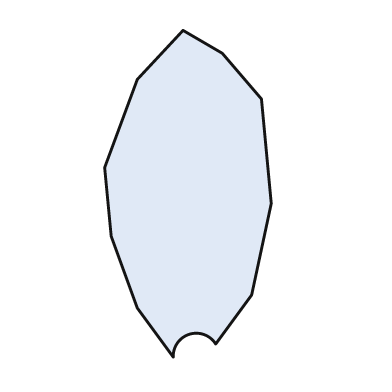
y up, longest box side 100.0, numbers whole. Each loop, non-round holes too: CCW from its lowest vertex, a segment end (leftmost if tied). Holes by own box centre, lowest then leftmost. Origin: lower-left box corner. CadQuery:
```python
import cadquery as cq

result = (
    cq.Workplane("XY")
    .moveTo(21.0, 0.0)
    .threePointArc((26.0, 7.0), (34.0, 4.0))
    .lineTo(45.0, 19.0)
    .lineTo(51.0, 47.0)
    .lineTo(48.0, 79.0)
    .lineTo(36.0, 93.0)
    .lineTo(24.0, 100.0)
    .lineTo(10.0, 85.0)
    .lineTo(0.0, 58.0)
    .lineTo(2.0, 37.0)
    .lineTo(10.0, 15.0)
    .close()
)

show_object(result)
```